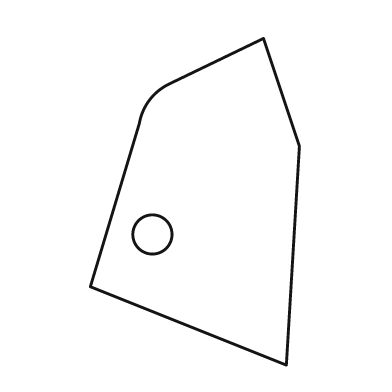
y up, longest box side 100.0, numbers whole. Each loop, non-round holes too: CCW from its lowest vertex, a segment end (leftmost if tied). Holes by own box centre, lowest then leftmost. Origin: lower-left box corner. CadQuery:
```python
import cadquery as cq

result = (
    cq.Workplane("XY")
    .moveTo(60.0, 0.0)
    .lineTo(64.0, 67.0)
    .lineTo(53.0, 100.0)
    .lineTo(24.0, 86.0)
    .threePointArc((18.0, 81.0), (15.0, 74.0))
    .lineTo(0.0, 24.0)
    .close()
    .moveTo(19.0, 40.0)
    .circle(6.0)
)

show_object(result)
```